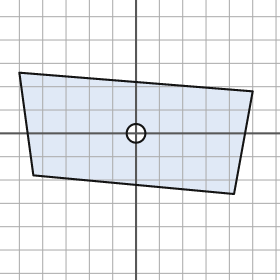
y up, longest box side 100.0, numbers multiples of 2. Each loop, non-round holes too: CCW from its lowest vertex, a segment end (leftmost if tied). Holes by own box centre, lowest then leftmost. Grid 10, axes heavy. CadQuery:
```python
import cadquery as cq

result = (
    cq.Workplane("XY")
    .moveTo(42.0, -26.0)
    .lineTo(50.0, 18.0)
    .lineTo(-50.0, 26.0)
    .lineTo(-44.0, -18.0)
    .close()
    .moveTo(0.0, 0.0)
    .circle(4.0)
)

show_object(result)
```